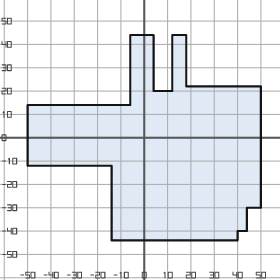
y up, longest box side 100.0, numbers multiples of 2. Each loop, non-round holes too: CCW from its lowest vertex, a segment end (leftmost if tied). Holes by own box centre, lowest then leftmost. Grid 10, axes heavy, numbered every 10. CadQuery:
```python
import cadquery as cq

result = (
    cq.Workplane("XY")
    .moveTo(-14.0, -44.0)
    .lineTo(40.0, -44.0)
    .lineTo(40.0, -40.0)
    .lineTo(44.0, -40.0)
    .lineTo(44.0, -30.0)
    .lineTo(50.0, -30.0)
    .lineTo(50.0, 22.0)
    .lineTo(18.0, 22.0)
    .lineTo(18.0, 44.0)
    .lineTo(12.0, 44.0)
    .lineTo(12.0, 20.0)
    .lineTo(4.0, 20.0)
    .lineTo(4.0, 44.0)
    .lineTo(-6.0, 44.0)
    .lineTo(-6.0, 14.0)
    .lineTo(-50.0, 14.0)
    .lineTo(-50.0, -12.0)
    .lineTo(-14.0, -12.0)
    .close()
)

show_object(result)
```